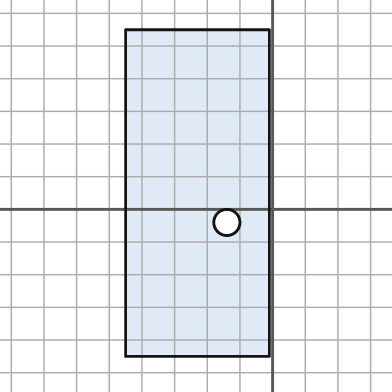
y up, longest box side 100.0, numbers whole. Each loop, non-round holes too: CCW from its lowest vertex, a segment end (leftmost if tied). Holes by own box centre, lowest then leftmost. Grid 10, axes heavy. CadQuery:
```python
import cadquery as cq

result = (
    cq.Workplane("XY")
    .moveTo(-45.0, -45.0)
    .lineTo(-1.0, -45.0)
    .lineTo(-1.0, 55.0)
    .lineTo(-45.0, 55.0)
    .close()
    .moveTo(-14.0, -4.0)
    .circle(4.0)
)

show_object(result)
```